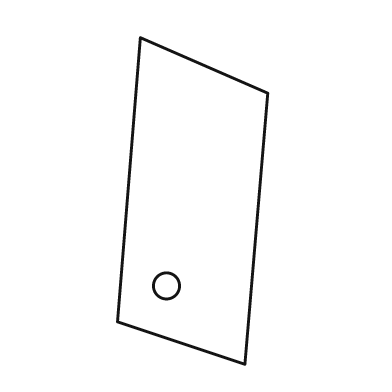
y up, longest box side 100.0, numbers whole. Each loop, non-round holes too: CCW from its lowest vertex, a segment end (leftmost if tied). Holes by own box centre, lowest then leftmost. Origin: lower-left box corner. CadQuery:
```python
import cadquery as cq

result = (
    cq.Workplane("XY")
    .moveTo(39.0, 0.0)
    .lineTo(46.0, 83.0)
    .lineTo(7.0, 100.0)
    .lineTo(0.0, 13.0)
    .close()
    .moveTo(15.0, 24.0)
    .circle(4.0)
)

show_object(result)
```